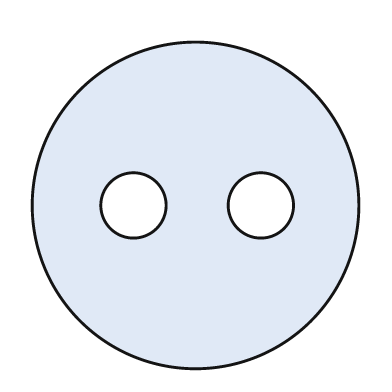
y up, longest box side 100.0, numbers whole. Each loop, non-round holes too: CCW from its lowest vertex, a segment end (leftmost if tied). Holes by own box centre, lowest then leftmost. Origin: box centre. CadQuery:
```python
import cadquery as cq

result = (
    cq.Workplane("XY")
    .moveTo(0.0, 0.0)
    .circle(50.0)
    .moveTo(-19.0, 0.0)
    .circle(10.0)
    .moveTo(20.0, 0.0)
    .circle(10.0)
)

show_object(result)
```